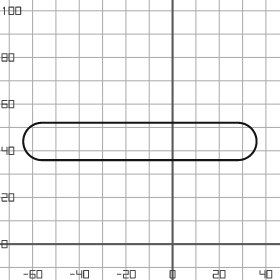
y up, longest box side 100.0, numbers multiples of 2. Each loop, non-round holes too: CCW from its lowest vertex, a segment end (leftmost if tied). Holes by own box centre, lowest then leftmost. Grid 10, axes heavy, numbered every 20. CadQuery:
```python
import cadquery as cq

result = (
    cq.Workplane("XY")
    .moveTo(-56.0, 36.0)
    .lineTo(28.0, 36.0)
    .threePointArc((36.0, 44.0), (28.0, 52.0))
    .lineTo(-56.0, 52.0)
    .threePointArc((-64.0, 44.0), (-56.0, 36.0))
    .close()
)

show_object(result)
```